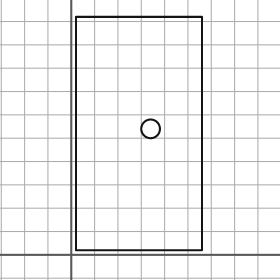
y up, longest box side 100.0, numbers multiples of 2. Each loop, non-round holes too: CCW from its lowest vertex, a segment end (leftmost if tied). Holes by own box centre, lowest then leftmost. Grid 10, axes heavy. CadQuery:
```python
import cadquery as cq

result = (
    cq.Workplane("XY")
    .moveTo(2.0, 2.0)
    .lineTo(56.0, 2.0)
    .lineTo(56.0, 102.0)
    .lineTo(2.0, 102.0)
    .close()
    .moveTo(34.0, 54.0)
    .circle(4.0)
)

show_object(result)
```